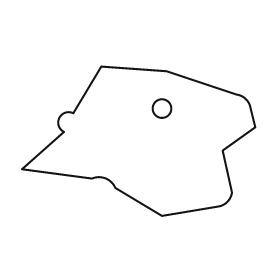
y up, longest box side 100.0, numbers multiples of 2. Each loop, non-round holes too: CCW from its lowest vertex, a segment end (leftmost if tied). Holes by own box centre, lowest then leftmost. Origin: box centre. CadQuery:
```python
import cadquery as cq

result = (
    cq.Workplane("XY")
    .moveTo(10.0, -32.0)
    .lineTo(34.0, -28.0)
    .threePointArc((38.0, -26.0), (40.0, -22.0))
    .lineTo(36.0, -4.0)
    .lineTo(50.0, 6.0)
    .lineTo(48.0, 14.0)
    .threePointArc((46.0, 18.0), (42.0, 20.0))
    .lineTo(12.0, 30.0)
    .lineTo(-16.0, 32.0)
    .lineTo(-28.0, 12.0)
    .threePointArc((-34.0, 10.0), (-32.0, 4.0))
    .lineTo(-50.0, -12.0)
    .lineTo(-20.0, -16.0)
    .threePointArc((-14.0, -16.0), (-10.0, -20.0))
    .close()
    .moveTo(10.0, 14.0)
    .circle(4.0)
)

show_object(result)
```